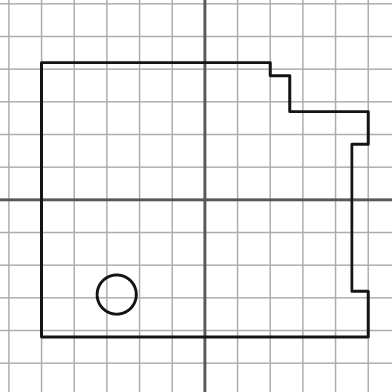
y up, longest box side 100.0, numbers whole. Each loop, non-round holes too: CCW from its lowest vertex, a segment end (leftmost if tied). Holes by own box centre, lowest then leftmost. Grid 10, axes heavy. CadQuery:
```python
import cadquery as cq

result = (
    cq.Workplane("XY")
    .moveTo(-50.0, -42.0)
    .lineTo(50.0, -42.0)
    .lineTo(50.0, -28.0)
    .lineTo(45.0, -28.0)
    .lineTo(45.0, 17.0)
    .lineTo(50.0, 17.0)
    .lineTo(50.0, 27.0)
    .lineTo(26.0, 27.0)
    .lineTo(26.0, 38.0)
    .lineTo(20.0, 38.0)
    .lineTo(20.0, 42.0)
    .lineTo(-50.0, 42.0)
    .close()
    .moveTo(-27.0, -29.0)
    .circle(6.0)
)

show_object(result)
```